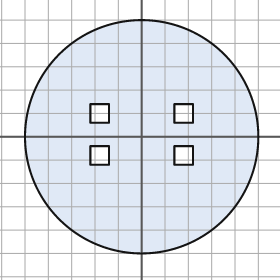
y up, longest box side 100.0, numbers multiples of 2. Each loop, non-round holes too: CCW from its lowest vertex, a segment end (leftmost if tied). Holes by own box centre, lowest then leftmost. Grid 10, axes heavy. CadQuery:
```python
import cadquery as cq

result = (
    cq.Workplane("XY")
    .moveTo(0.0, 0.0)
    .circle(50.0)
    .moveTo(-22.0, -12.0)
    .lineTo(-14.0, -12.0)
    .lineTo(-14.0, -4.0)
    .lineTo(-22.0, -4.0)
    .close()
    .moveTo(14.0, -12.0)
    .lineTo(22.0, -12.0)
    .lineTo(22.0, -4.0)
    .lineTo(14.0, -4.0)
    .close()
    .moveTo(-22.0, 6.0)
    .lineTo(-14.0, 6.0)
    .lineTo(-14.0, 14.0)
    .lineTo(-22.0, 14.0)
    .close()
    .moveTo(14.0, 6.0)
    .lineTo(22.0, 6.0)
    .lineTo(22.0, 14.0)
    .lineTo(14.0, 14.0)
    .close()
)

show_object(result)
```